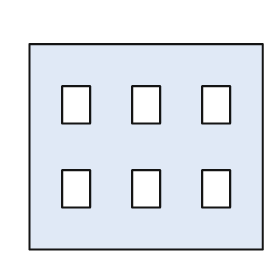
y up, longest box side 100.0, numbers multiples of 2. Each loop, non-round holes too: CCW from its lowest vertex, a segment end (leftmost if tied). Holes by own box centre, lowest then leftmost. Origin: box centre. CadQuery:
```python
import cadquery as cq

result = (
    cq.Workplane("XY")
    .moveTo(-50.0, -44.0)
    .lineTo(50.0, -44.0)
    .lineTo(50.0, 44.0)
    .lineTo(-50.0, 44.0)
    .close()
    .moveTo(-36.0, -26.0)
    .lineTo(-24.0, -26.0)
    .lineTo(-24.0, -10.0)
    .lineTo(-36.0, -10.0)
    .close()
    .moveTo(-6.0, -26.0)
    .lineTo(6.0, -26.0)
    .lineTo(6.0, -10.0)
    .lineTo(-6.0, -10.0)
    .close()
    .moveTo(24.0, -26.0)
    .lineTo(36.0, -26.0)
    .lineTo(36.0, -10.0)
    .lineTo(24.0, -10.0)
    .close()
    .moveTo(-36.0, 10.0)
    .lineTo(-24.0, 10.0)
    .lineTo(-24.0, 26.0)
    .lineTo(-36.0, 26.0)
    .close()
    .moveTo(-6.0, 10.0)
    .lineTo(6.0, 10.0)
    .lineTo(6.0, 26.0)
    .lineTo(-6.0, 26.0)
    .close()
    .moveTo(24.0, 10.0)
    .lineTo(36.0, 10.0)
    .lineTo(36.0, 26.0)
    .lineTo(24.0, 26.0)
    .close()
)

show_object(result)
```